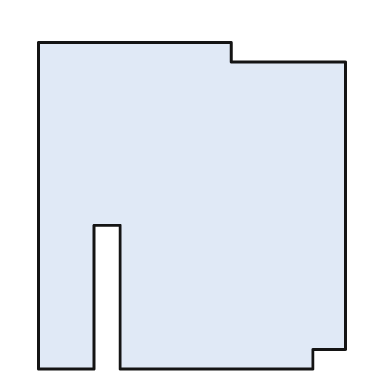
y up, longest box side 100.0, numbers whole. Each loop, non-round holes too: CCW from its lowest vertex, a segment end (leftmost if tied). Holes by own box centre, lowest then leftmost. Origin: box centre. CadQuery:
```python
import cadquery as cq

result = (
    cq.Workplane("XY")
    .moveTo(-47.0, -50.0)
    .lineTo(-30.0, -50.0)
    .lineTo(-30.0, -6.0)
    .lineTo(-22.0, -6.0)
    .lineTo(-22.0, -50.0)
    .lineTo(37.0, -50.0)
    .lineTo(37.0, -44.0)
    .lineTo(47.0, -44.0)
    .lineTo(47.0, 44.0)
    .lineTo(12.0, 44.0)
    .lineTo(12.0, 50.0)
    .lineTo(-47.0, 50.0)
    .close()
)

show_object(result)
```